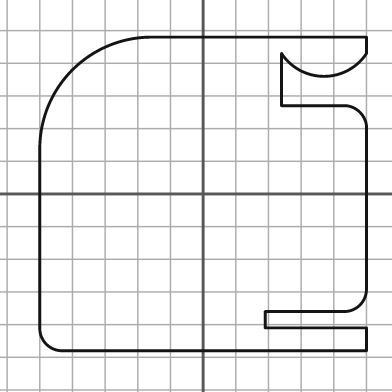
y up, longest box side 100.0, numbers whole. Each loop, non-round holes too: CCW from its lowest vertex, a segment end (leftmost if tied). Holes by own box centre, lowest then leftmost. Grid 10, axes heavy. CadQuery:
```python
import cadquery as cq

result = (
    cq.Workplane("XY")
    .moveTo(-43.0, -48.0)
    .lineTo(50.0, -48.0)
    .lineTo(50.0, -41.0)
    .lineTo(19.0, -41.0)
    .lineTo(19.0, -36.0)
    .lineTo(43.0, -36.0)
    .threePointArc((48.0, -34.0), (50.0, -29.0))
    .lineTo(50.0, 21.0)
    .threePointArc((48.0, 25.0), (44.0, 27.0))
    .lineTo(24.0, 27.0)
    .lineTo(24.0, 43.0)
    .threePointArc((37.0, 36.0), (50.0, 43.0))
    .lineTo(50.0, 48.0)
    .lineTo(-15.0, 48.0)
    .threePointArc((-40.0, 38.0), (-50.0, 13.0))
    .lineTo(-50.0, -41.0)
    .threePointArc((-48.0, -46.0), (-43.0, -48.0))
    .close()
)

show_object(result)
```